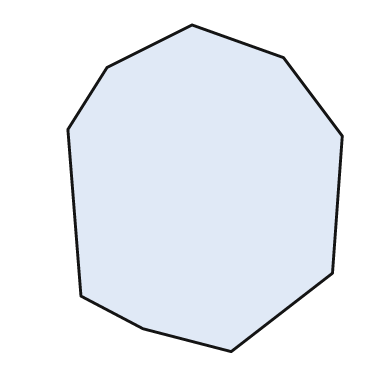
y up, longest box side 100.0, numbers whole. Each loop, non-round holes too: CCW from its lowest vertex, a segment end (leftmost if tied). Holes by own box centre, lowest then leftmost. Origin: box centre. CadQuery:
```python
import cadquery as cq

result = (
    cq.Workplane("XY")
    .moveTo(8.0, -50.0)
    .lineTo(39.0, -26.0)
    .lineTo(42.0, 16.0)
    .lineTo(24.0, 40.0)
    .lineTo(-4.0, 50.0)
    .lineTo(-30.0, 37.0)
    .lineTo(-42.0, 18.0)
    .lineTo(-38.0, -33.0)
    .lineTo(-19.0, -43.0)
    .close()
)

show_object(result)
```